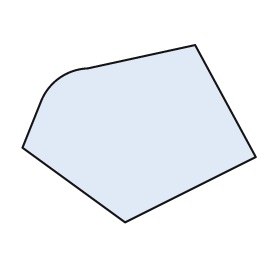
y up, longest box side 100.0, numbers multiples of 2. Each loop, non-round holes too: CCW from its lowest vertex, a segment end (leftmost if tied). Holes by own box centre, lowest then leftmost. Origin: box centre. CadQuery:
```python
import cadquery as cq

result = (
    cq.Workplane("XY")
    .moveTo(-6.0, -38.0)
    .lineTo(50.0, -10.0)
    .lineTo(24.0, 38.0)
    .lineTo(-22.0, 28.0)
    .threePointArc((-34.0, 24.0), (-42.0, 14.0))
    .lineTo(-50.0, -6.0)
    .close()
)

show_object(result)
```